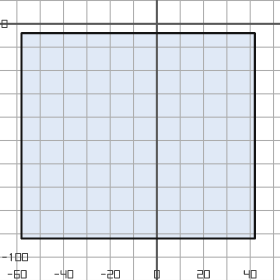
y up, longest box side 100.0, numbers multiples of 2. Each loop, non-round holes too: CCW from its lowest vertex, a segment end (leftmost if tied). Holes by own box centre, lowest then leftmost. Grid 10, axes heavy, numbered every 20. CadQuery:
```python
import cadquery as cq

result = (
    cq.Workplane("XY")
    .moveTo(-58.0, -92.0)
    .lineTo(42.0, -92.0)
    .lineTo(42.0, -4.0)
    .lineTo(-58.0, -4.0)
    .close()
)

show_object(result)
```